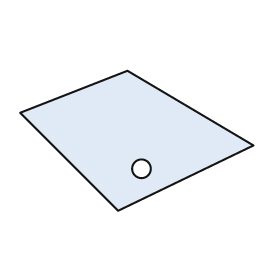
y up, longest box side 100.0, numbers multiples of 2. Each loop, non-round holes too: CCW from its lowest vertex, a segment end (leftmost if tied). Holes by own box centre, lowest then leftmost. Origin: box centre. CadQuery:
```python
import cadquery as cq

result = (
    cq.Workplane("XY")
    .moveTo(-8.0, -30.0)
    .lineTo(50.0, -2.0)
    .lineTo(-4.0, 30.0)
    .lineTo(-50.0, 12.0)
    .close()
    .moveTo(2.0, -12.0)
    .circle(4.0)
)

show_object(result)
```